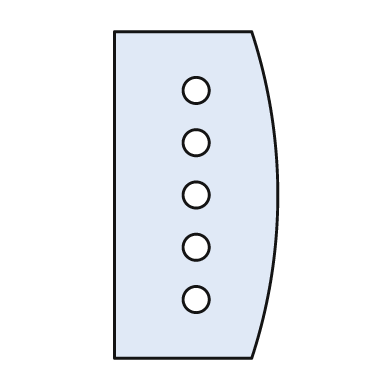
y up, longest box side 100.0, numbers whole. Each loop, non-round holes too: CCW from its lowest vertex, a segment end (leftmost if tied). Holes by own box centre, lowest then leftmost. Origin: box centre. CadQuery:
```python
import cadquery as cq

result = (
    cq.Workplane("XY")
    .moveTo(-25.0, -50.0)
    .lineTo(17.0, -50.0)
    .threePointArc((25.0, 0.0), (17.0, 50.0))
    .lineTo(-25.0, 50.0)
    .close()
    .moveTo(0.0, -32.0)
    .circle(4.0)
    .moveTo(0.0, -16.0)
    .circle(4.0)
    .moveTo(0.0, 0.0)
    .circle(4.0)
    .moveTo(0.0, 16.0)
    .circle(4.0)
    .moveTo(0.0, 32.0)
    .circle(4.0)
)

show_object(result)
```